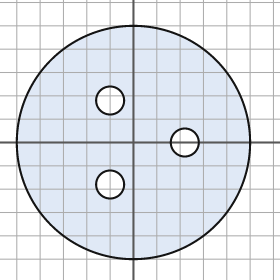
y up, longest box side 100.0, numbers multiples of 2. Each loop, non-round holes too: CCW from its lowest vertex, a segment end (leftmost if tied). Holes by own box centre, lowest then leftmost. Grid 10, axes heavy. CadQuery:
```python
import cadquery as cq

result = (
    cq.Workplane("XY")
    .moveTo(0.0, 0.0)
    .circle(50.0)
    .moveTo(-10.0, -18.0)
    .circle(6.0)
    .moveTo(22.0, 0.0)
    .circle(6.0)
    .moveTo(-10.0, 18.0)
    .circle(6.0)
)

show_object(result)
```